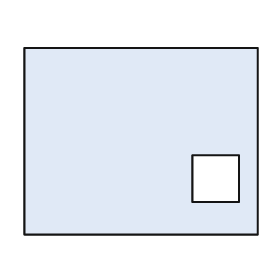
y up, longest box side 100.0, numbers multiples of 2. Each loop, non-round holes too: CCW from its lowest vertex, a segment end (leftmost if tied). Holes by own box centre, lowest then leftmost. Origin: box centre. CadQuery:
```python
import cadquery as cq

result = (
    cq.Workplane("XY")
    .moveTo(-50.0, -40.0)
    .lineTo(50.0, -40.0)
    .lineTo(50.0, 40.0)
    .lineTo(-50.0, 40.0)
    .close()
    .moveTo(22.0, -26.0)
    .lineTo(42.0, -26.0)
    .lineTo(42.0, -6.0)
    .lineTo(22.0, -6.0)
    .close()
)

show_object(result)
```